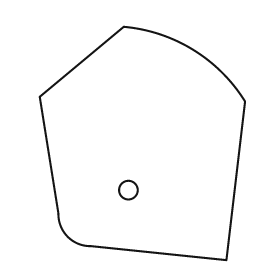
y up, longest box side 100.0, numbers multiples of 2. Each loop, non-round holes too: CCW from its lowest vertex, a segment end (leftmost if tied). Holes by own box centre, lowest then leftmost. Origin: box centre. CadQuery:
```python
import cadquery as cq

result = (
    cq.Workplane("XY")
    .moveTo(36.0, -50.0)
    .lineTo(44.0, 18.0)
    .threePointArc((22.0, 40.0), (-8.0, 50.0))
    .lineTo(-44.0, 20.0)
    .lineTo(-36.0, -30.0)
    .threePointArc((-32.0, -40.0), (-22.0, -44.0))
    .close()
    .moveTo(-6.0, -20.0)
    .circle(4.0)
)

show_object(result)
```